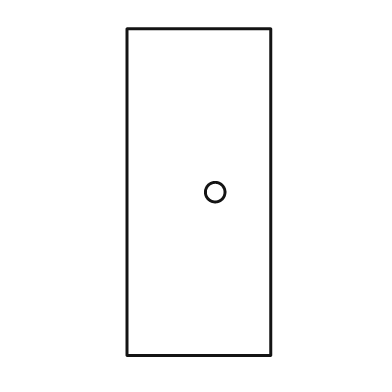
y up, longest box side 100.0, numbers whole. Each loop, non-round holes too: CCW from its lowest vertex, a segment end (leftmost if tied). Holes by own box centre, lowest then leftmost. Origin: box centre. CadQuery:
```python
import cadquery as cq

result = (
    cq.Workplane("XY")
    .moveTo(-22.0, -50.0)
    .lineTo(22.0, -50.0)
    .lineTo(22.0, 50.0)
    .lineTo(-22.0, 50.0)
    .close()
    .moveTo(5.0, 0.0)
    .circle(3.0)
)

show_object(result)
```